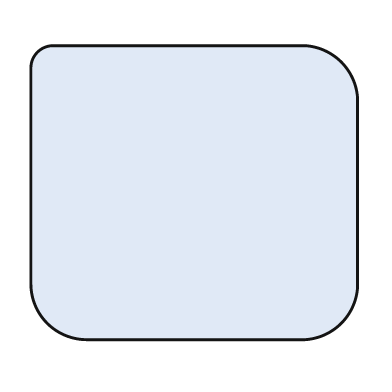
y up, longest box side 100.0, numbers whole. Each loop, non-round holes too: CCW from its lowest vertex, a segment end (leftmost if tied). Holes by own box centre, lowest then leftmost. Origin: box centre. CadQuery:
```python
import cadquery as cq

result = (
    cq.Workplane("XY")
    .moveTo(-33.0, -45.0)
    .lineTo(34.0, -45.0)
    .threePointArc((45.0, -40.0), (50.0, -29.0))
    .lineTo(50.0, 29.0)
    .threePointArc((45.0, 40.0), (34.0, 45.0))
    .lineTo(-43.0, 45.0)
    .threePointArc((-48.0, 43.0), (-50.0, 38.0))
    .lineTo(-50.0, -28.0)
    .threePointArc((-45.0, -40.0), (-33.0, -45.0))
    .close()
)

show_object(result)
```